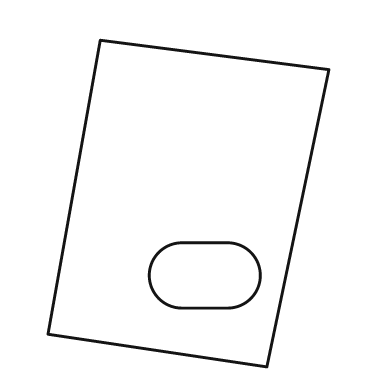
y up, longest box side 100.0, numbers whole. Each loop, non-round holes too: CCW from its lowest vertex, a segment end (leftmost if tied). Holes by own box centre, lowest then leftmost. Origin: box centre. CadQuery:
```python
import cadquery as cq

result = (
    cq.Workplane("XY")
    .moveTo(24.0, -50.0)
    .lineTo(43.0, 41.0)
    .lineTo(-27.0, 50.0)
    .lineTo(-43.0, -40.0)
    .close()
    .moveTo(-2.0, -32.0)
    .lineTo(12.0, -32.0)
    .threePointArc((22.0, -22.0), (12.0, -12.0))
    .lineTo(-2.0, -12.0)
    .threePointArc((-12.0, -22.0), (-2.0, -32.0))
    .close()
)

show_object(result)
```